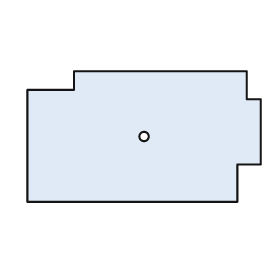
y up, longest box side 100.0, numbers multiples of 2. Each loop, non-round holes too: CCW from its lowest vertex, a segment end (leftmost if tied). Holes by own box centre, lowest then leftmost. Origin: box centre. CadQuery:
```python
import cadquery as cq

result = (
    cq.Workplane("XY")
    .moveTo(-50.0, -28.0)
    .lineTo(40.0, -28.0)
    .lineTo(40.0, -12.0)
    .lineTo(50.0, -12.0)
    .lineTo(50.0, 16.0)
    .lineTo(44.0, 16.0)
    .lineTo(44.0, 28.0)
    .lineTo(-30.0, 28.0)
    .lineTo(-30.0, 20.0)
    .lineTo(-50.0, 20.0)
    .close()
    .moveTo(0.0, 0.0)
    .circle(2.0)
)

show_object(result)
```